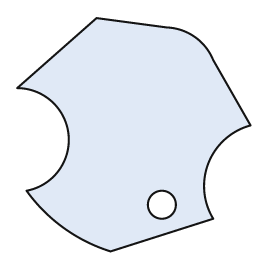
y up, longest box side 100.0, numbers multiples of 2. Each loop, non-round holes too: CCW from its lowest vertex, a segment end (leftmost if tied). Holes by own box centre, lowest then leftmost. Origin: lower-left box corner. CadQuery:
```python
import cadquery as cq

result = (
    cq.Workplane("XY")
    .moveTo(40.0, 0.0)
    .lineTo(84.0, 14.0)
    .threePointArc((82.0, 38.0), (100.0, 54.0))
    .lineTo(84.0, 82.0)
    .threePointArc((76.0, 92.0), (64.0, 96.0))
    .lineTo(34.0, 100.0)
    .lineTo(0.0, 70.0)
    .threePointArc((22.0, 50.0), (4.0, 26.0))
    .threePointArc((20.0, 10.0), (40.0, 0.0))
    .close()
    .moveTo(62.0, 20.0)
    .circle(6.0)
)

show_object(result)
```